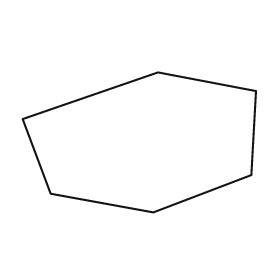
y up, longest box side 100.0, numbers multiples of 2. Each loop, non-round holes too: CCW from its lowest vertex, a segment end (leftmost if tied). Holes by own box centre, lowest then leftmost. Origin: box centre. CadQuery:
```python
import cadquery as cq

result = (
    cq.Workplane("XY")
    .moveTo(6.0, -30.0)
    .lineTo(48.0, -14.0)
    .lineTo(50.0, 22.0)
    .lineTo(8.0, 30.0)
    .lineTo(-50.0, 10.0)
    .lineTo(-38.0, -22.0)
    .close()
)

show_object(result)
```